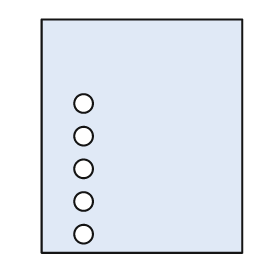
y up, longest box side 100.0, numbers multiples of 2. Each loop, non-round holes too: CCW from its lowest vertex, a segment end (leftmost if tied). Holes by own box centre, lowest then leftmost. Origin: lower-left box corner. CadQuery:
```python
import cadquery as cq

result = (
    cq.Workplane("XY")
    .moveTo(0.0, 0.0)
    .lineTo(86.0, 0.0)
    .lineTo(86.0, 100.0)
    .lineTo(0.0, 100.0)
    .close()
    .moveTo(18.0, 8.0)
    .circle(4.0)
    .moveTo(18.0, 22.0)
    .circle(4.0)
    .moveTo(18.0, 36.0)
    .circle(4.0)
    .moveTo(18.0, 50.0)
    .circle(4.0)
    .moveTo(18.0, 64.0)
    .circle(4.0)
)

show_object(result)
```